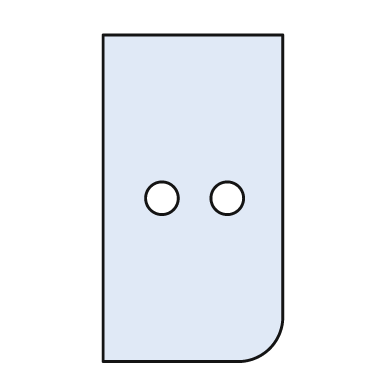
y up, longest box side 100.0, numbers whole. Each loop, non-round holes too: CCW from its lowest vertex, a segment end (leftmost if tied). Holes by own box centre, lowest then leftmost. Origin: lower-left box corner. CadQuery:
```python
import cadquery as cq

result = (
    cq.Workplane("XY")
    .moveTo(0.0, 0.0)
    .lineTo(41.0, 0.0)
    .threePointArc((51.0, 4.0), (55.0, 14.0))
    .lineTo(55.0, 100.0)
    .lineTo(0.0, 100.0)
    .close()
    .moveTo(18.0, 50.0)
    .circle(5.0)
    .moveTo(38.0, 50.0)
    .circle(5.0)
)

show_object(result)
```